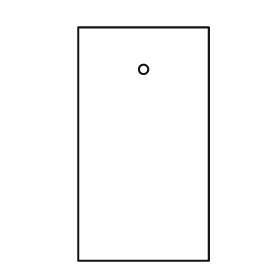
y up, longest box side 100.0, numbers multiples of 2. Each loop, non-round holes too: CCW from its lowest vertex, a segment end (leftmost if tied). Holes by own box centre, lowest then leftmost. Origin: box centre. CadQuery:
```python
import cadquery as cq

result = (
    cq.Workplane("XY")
    .moveTo(-28.0, -50.0)
    .lineTo(28.0, -50.0)
    .lineTo(28.0, 50.0)
    .lineTo(-28.0, 50.0)
    .close()
    .moveTo(0.0, 32.0)
    .circle(2.0)
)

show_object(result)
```